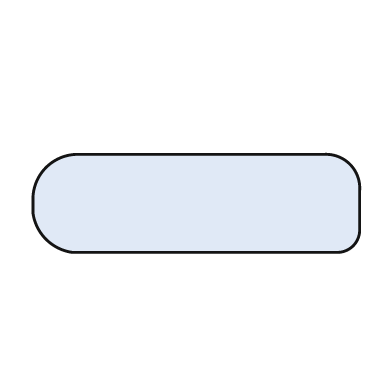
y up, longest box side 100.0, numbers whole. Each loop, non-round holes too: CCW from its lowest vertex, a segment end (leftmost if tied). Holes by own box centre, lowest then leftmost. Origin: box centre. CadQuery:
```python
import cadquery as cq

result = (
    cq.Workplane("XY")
    .moveTo(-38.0, -15.0)
    .lineTo(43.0, -15.0)
    .threePointArc((48.0, -13.0), (50.0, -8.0))
    .lineTo(50.0, 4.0)
    .threePointArc((47.0, 12.0), (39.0, 15.0))
    .lineTo(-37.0, 15.0)
    .threePointArc((-46.0, 11.0), (-50.0, 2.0))
    .lineTo(-50.0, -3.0)
    .threePointArc((-46.0, -11.0), (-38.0, -15.0))
    .close()
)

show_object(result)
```